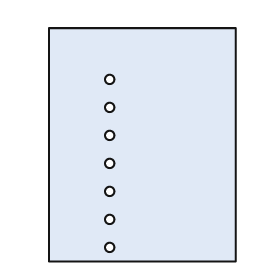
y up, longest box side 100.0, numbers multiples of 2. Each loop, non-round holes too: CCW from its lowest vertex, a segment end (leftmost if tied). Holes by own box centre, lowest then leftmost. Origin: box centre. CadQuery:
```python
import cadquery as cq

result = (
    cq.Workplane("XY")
    .moveTo(-40.0, -50.0)
    .lineTo(40.0, -50.0)
    .lineTo(40.0, 50.0)
    .lineTo(-40.0, 50.0)
    .close()
    .moveTo(-14.0, -44.0)
    .circle(2.0)
    .moveTo(-14.0, -32.0)
    .circle(2.0)
    .moveTo(-14.0, -20.0)
    .circle(2.0)
    .moveTo(-14.0, -8.0)
    .circle(2.0)
    .moveTo(-14.0, 4.0)
    .circle(2.0)
    .moveTo(-14.0, 16.0)
    .circle(2.0)
    .moveTo(-14.0, 28.0)
    .circle(2.0)
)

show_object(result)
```